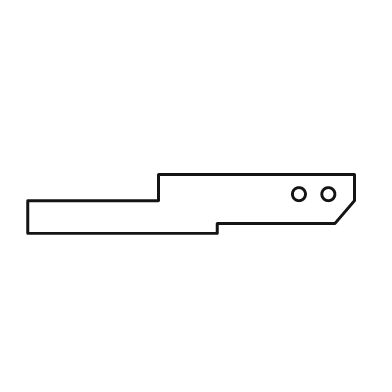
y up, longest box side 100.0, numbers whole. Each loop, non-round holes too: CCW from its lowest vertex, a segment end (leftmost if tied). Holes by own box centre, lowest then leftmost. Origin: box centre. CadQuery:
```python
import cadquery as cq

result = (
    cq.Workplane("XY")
    .moveTo(-50.0, -9.0)
    .lineTo(8.0, -9.0)
    .lineTo(8.0, -6.0)
    .lineTo(44.0, -6.0)
    .lineTo(50.0, 1.0)
    .lineTo(50.0, 9.0)
    .lineTo(-10.0, 9.0)
    .lineTo(-10.0, 1.0)
    .lineTo(-50.0, 1.0)
    .close()
    .moveTo(33.0, 3.0)
    .circle(2.0)
    .moveTo(42.0, 3.0)
    .circle(2.0)
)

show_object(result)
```